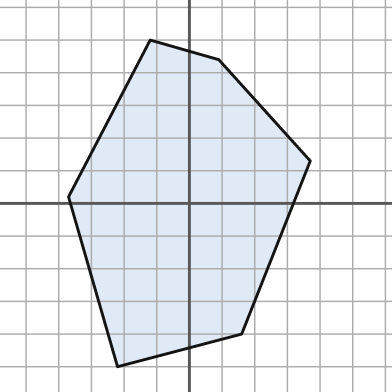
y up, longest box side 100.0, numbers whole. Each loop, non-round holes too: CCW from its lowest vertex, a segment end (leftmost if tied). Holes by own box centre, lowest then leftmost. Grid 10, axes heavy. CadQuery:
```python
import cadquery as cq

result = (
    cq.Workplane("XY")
    .moveTo(-22.0, -50.0)
    .lineTo(16.0, -40.0)
    .lineTo(37.0, 13.0)
    .lineTo(9.0, 44.0)
    .lineTo(-12.0, 50.0)
    .lineTo(-37.0, 2.0)
    .close()
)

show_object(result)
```